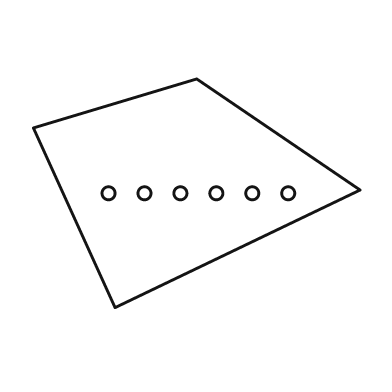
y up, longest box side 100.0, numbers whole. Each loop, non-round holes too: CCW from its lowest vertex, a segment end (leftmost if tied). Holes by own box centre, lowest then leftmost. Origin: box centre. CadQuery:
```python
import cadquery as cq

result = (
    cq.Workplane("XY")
    .moveTo(-25.0, -35.0)
    .lineTo(50.0, 1.0)
    .lineTo(0.0, 35.0)
    .lineTo(-50.0, 20.0)
    .close()
    .moveTo(-27.0, 0.0)
    .circle(2.0)
    .moveTo(-16.0, 0.0)
    .circle(2.0)
    .moveTo(-5.0, 0.0)
    .circle(2.0)
    .moveTo(6.0, 0.0)
    .circle(2.0)
    .moveTo(17.0, 0.0)
    .circle(2.0)
    .moveTo(28.0, 0.0)
    .circle(2.0)
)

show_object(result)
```